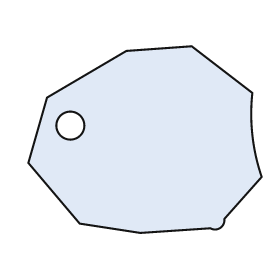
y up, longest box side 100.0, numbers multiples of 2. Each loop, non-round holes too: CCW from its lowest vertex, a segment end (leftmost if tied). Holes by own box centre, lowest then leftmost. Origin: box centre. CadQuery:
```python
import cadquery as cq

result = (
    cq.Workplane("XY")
    .moveTo(-2.0, -40.0)
    .lineTo(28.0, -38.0)
    .threePointArc((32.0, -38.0), (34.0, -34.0))
    .lineTo(50.0, -16.0)
    .threePointArc((46.0, 2.0), (46.0, 20.0))
    .lineTo(20.0, 40.0)
    .lineTo(-8.0, 38.0)
    .lineTo(-42.0, 18.0)
    .lineTo(-50.0, -10.0)
    .lineTo(-28.0, -36.0)
    .close()
    .moveTo(-32.0, 6.0)
    .circle(6.0)
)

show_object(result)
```